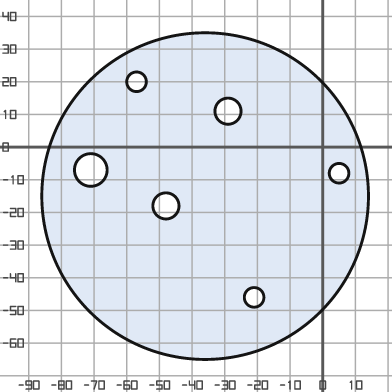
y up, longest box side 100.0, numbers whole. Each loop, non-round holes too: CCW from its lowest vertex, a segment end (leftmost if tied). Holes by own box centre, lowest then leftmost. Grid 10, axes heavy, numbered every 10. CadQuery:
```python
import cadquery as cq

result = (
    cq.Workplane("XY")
    .moveTo(-36.0, -15.0)
    .circle(50.0)
    .moveTo(-21.0, -46.0)
    .circle(3.0)
    .moveTo(-48.0, -18.0)
    .circle(4.0)
    .moveTo(5.0, -8.0)
    .circle(3.0)
    .moveTo(-71.0, -7.0)
    .circle(5.0)
    .moveTo(-29.0, 11.0)
    .circle(4.0)
    .moveTo(-57.0, 20.0)
    .circle(3.0)
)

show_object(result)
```